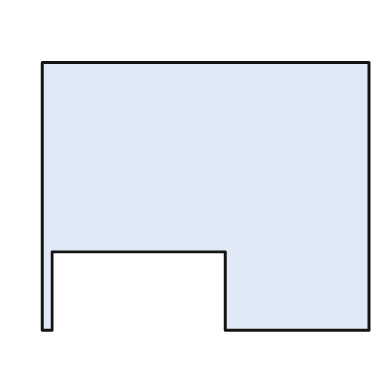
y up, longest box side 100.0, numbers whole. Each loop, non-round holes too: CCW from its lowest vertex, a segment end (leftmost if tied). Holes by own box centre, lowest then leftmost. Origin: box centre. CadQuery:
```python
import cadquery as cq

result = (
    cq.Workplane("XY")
    .moveTo(-50.0, -41.0)
    .lineTo(-47.0, -41.0)
    .lineTo(-47.0, -17.0)
    .lineTo(6.0, -17.0)
    .lineTo(6.0, -41.0)
    .lineTo(50.0, -41.0)
    .lineTo(50.0, 41.0)
    .lineTo(-50.0, 41.0)
    .close()
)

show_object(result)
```